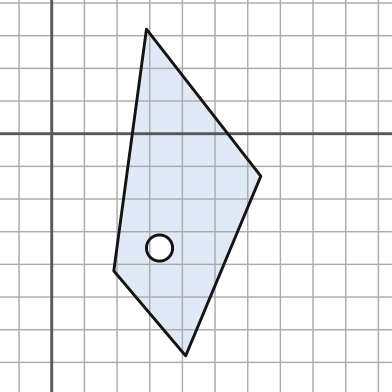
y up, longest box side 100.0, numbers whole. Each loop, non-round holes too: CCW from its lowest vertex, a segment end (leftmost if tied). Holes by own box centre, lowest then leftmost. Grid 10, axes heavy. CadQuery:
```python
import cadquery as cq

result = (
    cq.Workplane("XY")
    .moveTo(41.0, -68.0)
    .lineTo(64.0, -13.0)
    .lineTo(29.0, 32.0)
    .lineTo(19.0, -42.0)
    .close()
    .moveTo(33.0, -35.0)
    .circle(4.0)
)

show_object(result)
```